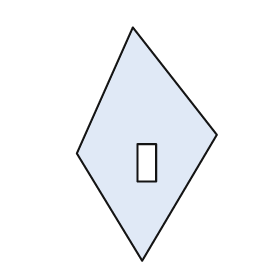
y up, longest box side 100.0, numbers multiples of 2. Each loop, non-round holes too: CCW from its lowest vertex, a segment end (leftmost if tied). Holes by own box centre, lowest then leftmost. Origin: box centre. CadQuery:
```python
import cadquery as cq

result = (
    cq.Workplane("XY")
    .moveTo(-2.0, -50.0)
    .lineTo(30.0, 4.0)
    .lineTo(-6.0, 50.0)
    .lineTo(-30.0, -4.0)
    .close()
    .moveTo(-4.0, -16.0)
    .lineTo(4.0, -16.0)
    .lineTo(4.0, 0.0)
    .lineTo(-4.0, 0.0)
    .close()
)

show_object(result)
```